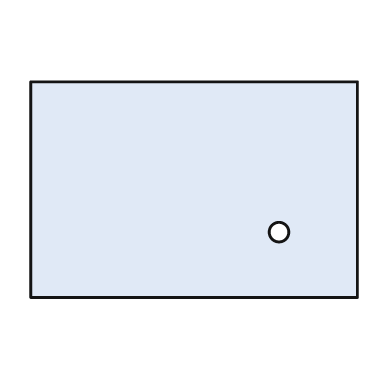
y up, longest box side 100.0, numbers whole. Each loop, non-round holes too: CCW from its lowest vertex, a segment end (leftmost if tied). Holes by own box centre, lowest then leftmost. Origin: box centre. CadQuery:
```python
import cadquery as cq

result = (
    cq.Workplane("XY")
    .moveTo(-50.0, -33.0)
    .lineTo(50.0, -33.0)
    .lineTo(50.0, 33.0)
    .lineTo(-50.0, 33.0)
    .close()
    .moveTo(26.0, -13.0)
    .circle(3.0)
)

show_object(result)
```